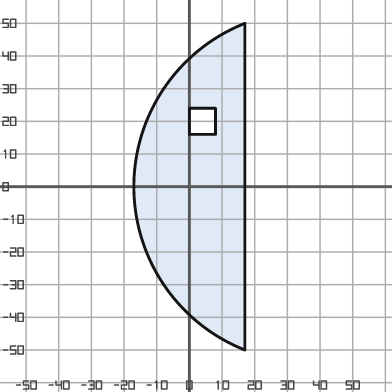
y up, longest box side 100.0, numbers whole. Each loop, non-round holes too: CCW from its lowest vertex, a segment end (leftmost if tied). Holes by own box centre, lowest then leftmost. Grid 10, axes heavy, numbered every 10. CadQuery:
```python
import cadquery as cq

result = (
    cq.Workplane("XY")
    .moveTo(17.0, -50.0)
    .lineTo(17.0, 50.0)
    .threePointArc((-17.0, 0.0), (17.0, -50.0))
    .close()
    .moveTo(0.0, 16.0)
    .lineTo(8.0, 16.0)
    .lineTo(8.0, 24.0)
    .lineTo(0.0, 24.0)
    .close()
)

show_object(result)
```